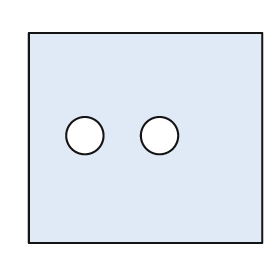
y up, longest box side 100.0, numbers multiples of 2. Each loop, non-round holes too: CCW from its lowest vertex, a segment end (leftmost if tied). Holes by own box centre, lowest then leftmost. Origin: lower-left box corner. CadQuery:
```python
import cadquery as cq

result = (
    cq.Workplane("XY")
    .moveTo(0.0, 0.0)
    .lineTo(100.0, 0.0)
    .lineTo(100.0, 90.0)
    .lineTo(0.0, 90.0)
    .close()
    .moveTo(24.0, 46.0)
    .circle(8.0)
    .moveTo(56.0, 46.0)
    .circle(8.0)
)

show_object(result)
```